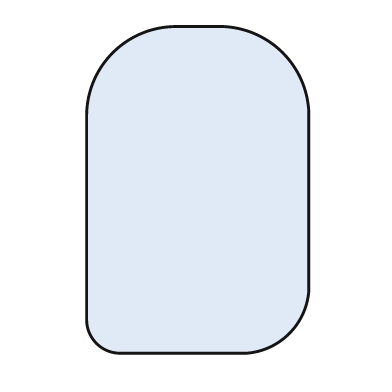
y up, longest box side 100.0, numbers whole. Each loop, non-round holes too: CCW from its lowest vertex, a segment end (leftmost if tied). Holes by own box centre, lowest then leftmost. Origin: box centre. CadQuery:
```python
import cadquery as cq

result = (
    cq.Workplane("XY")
    .moveTo(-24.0, -50.0)
    .lineTo(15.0, -50.0)
    .threePointArc((28.0, -44.0), (34.0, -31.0))
    .lineTo(34.0, 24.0)
    .threePointArc((26.0, 42.0), (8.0, 50.0))
    .lineTo(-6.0, 50.0)
    .threePointArc((-26.0, 42.0), (-34.0, 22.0))
    .lineTo(-34.0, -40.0)
    .threePointArc((-31.0, -47.0), (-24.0, -50.0))
    .close()
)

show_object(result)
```